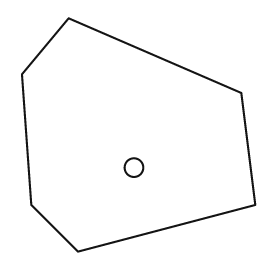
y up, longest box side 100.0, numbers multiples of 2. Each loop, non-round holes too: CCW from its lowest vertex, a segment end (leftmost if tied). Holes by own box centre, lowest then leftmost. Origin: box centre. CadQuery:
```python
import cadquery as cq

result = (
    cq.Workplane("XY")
    .moveTo(-26.0, -50.0)
    .lineTo(50.0, -30.0)
    .lineTo(44.0, 18.0)
    .lineTo(-30.0, 50.0)
    .lineTo(-50.0, 26.0)
    .lineTo(-46.0, -30.0)
    .close()
    .moveTo(-2.0, -14.0)
    .circle(4.0)
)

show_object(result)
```